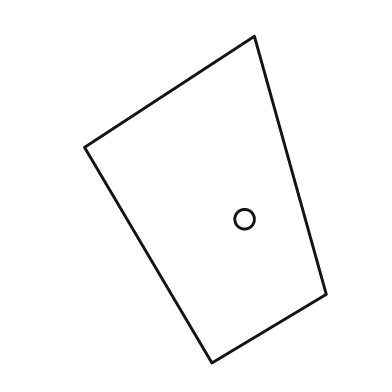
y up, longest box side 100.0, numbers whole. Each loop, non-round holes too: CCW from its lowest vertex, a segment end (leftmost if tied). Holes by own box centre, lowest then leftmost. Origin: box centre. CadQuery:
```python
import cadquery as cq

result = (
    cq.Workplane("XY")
    .moveTo(2.0, -50.0)
    .lineTo(37.0, -29.0)
    .lineTo(15.0, 50.0)
    .lineTo(-37.0, 16.0)
    .close()
    .moveTo(12.0, -6.0)
    .circle(3.0)
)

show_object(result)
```